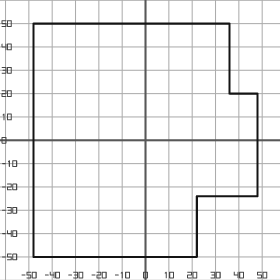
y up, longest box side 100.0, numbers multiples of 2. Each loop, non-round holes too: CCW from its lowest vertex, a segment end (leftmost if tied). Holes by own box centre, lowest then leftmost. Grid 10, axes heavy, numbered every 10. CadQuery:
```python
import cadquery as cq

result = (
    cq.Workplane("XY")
    .moveTo(-48.0, -50.0)
    .lineTo(22.0, -50.0)
    .lineTo(22.0, -24.0)
    .lineTo(48.0, -24.0)
    .lineTo(48.0, 20.0)
    .lineTo(36.0, 20.0)
    .lineTo(36.0, 50.0)
    .lineTo(-48.0, 50.0)
    .close()
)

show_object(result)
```